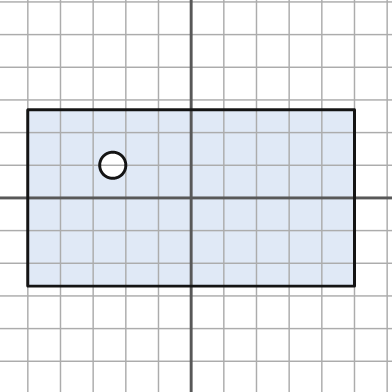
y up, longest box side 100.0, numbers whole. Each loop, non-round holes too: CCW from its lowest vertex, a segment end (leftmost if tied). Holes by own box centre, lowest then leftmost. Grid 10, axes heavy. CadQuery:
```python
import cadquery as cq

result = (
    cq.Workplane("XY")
    .moveTo(-50.0, -27.0)
    .lineTo(50.0, -27.0)
    .lineTo(50.0, 27.0)
    .lineTo(-50.0, 27.0)
    .close()
    .moveTo(-24.0, 10.0)
    .circle(4.0)
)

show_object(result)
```